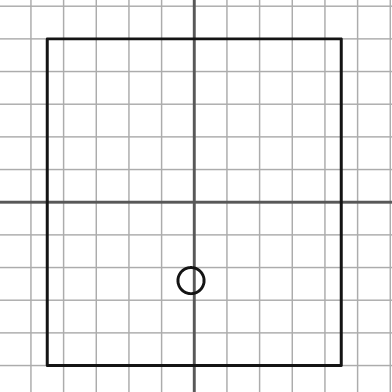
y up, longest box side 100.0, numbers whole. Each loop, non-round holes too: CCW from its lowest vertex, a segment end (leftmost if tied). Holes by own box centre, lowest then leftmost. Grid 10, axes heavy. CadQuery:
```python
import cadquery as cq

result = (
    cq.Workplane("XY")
    .moveTo(-45.0, -50.0)
    .lineTo(45.0, -50.0)
    .lineTo(45.0, 50.0)
    .lineTo(-45.0, 50.0)
    .close()
    .moveTo(-1.0, -24.0)
    .circle(4.0)
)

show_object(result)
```